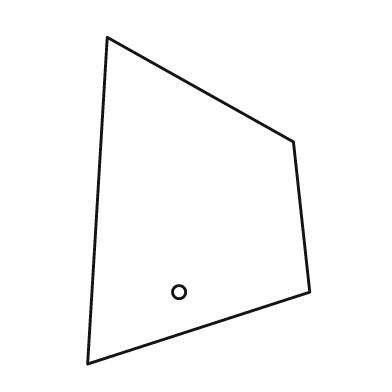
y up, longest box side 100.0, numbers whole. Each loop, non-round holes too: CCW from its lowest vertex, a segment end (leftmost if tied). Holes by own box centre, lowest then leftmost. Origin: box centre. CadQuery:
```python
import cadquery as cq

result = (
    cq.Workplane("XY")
    .moveTo(-34.0, -50.0)
    .lineTo(34.0, -28.0)
    .lineTo(29.0, 18.0)
    .lineTo(-28.0, 50.0)
    .close()
    .moveTo(-6.0, -28.0)
    .circle(2.0)
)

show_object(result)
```